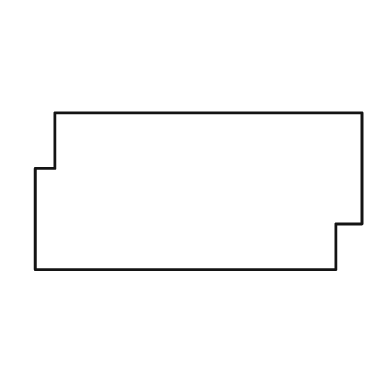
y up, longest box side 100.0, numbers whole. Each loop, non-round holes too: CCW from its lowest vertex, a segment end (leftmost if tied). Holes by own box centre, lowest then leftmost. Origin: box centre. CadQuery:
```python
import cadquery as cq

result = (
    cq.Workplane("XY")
    .moveTo(-50.0, -24.0)
    .lineTo(42.0, -24.0)
    .lineTo(42.0, -10.0)
    .lineTo(50.0, -10.0)
    .lineTo(50.0, 24.0)
    .lineTo(-44.0, 24.0)
    .lineTo(-44.0, 7.0)
    .lineTo(-50.0, 7.0)
    .close()
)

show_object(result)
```